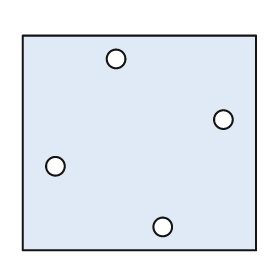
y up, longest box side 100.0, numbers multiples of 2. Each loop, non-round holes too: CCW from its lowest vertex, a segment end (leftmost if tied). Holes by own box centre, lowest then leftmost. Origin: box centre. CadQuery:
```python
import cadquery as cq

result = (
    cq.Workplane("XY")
    .moveTo(-50.0, -46.0)
    .lineTo(50.0, -46.0)
    .lineTo(50.0, 46.0)
    .lineTo(-50.0, 46.0)
    .close()
    .moveTo(10.0, -36.0)
    .circle(4.0)
    .moveTo(-36.0, -10.0)
    .circle(4.0)
    .moveTo(36.0, 10.0)
    .circle(4.0)
    .moveTo(-10.0, 36.0)
    .circle(4.0)
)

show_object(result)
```